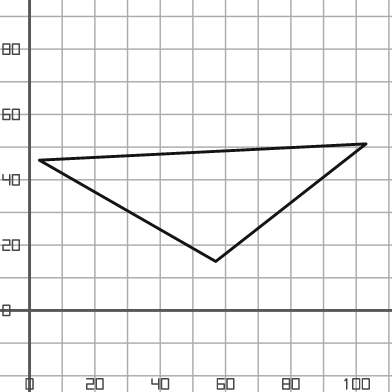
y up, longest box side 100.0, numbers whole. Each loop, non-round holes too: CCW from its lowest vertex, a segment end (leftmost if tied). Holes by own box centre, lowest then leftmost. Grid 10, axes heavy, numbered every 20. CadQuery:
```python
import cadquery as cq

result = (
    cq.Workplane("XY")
    .moveTo(57.0, 15.0)
    .lineTo(103.0, 51.0)
    .lineTo(3.0, 46.0)
    .close()
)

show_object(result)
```